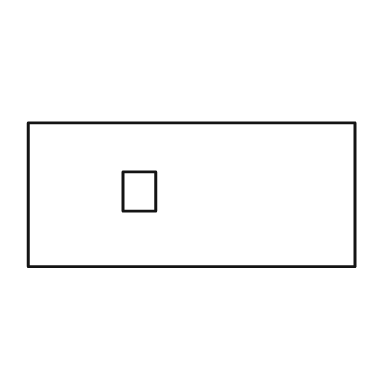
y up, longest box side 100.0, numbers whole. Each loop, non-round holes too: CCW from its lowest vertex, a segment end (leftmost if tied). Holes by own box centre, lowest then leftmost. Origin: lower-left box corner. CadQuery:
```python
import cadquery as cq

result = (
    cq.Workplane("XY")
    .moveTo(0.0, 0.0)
    .lineTo(100.0, 0.0)
    .lineTo(100.0, 44.0)
    .lineTo(0.0, 44.0)
    .close()
    .moveTo(29.0, 17.0)
    .lineTo(39.0, 17.0)
    .lineTo(39.0, 29.0)
    .lineTo(29.0, 29.0)
    .close()
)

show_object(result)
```